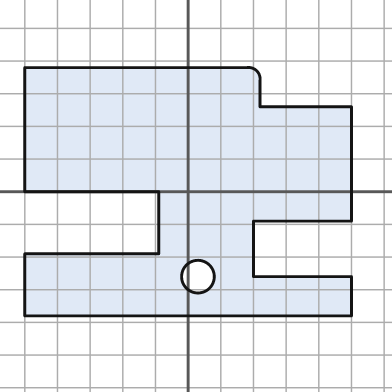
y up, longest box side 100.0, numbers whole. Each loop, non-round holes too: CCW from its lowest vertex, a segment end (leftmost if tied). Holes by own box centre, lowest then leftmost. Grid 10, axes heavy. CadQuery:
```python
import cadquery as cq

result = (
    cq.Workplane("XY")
    .moveTo(-50.0, -38.0)
    .lineTo(50.0, -38.0)
    .lineTo(50.0, -26.0)
    .lineTo(20.0, -26.0)
    .lineTo(20.0, -9.0)
    .lineTo(50.0, -9.0)
    .lineTo(50.0, 26.0)
    .lineTo(22.0, 26.0)
    .lineTo(22.0, 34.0)
    .threePointArc((21.0, 37.0), (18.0, 38.0))
    .lineTo(-50.0, 38.0)
    .lineTo(-50.0, 0.0)
    .lineTo(-9.0, 0.0)
    .lineTo(-9.0, -19.0)
    .lineTo(-50.0, -19.0)
    .close()
    .moveTo(3.0, -26.0)
    .circle(5.0)
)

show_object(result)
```